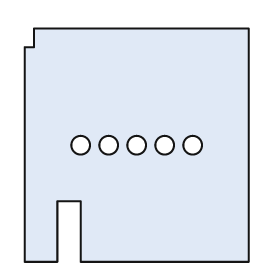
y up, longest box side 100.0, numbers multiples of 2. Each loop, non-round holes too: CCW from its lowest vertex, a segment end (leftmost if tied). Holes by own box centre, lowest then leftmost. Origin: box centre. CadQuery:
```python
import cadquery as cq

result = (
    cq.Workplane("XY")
    .moveTo(-48.0, -50.0)
    .lineTo(-34.0, -50.0)
    .lineTo(-34.0, -24.0)
    .lineTo(-24.0, -24.0)
    .lineTo(-24.0, -50.0)
    .lineTo(48.0, -50.0)
    .lineTo(48.0, 50.0)
    .lineTo(-44.0, 50.0)
    .lineTo(-44.0, 42.0)
    .lineTo(-48.0, 42.0)
    .close()
    .moveTo(-24.0, 0.0)
    .circle(4.0)
    .moveTo(-12.0, 0.0)
    .circle(4.0)
    .moveTo(0.0, 0.0)
    .circle(4.0)
    .moveTo(12.0, 0.0)
    .circle(4.0)
    .moveTo(24.0, 0.0)
    .circle(4.0)
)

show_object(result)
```